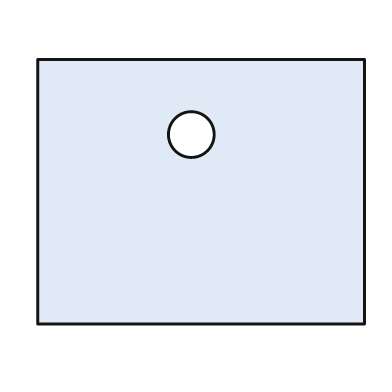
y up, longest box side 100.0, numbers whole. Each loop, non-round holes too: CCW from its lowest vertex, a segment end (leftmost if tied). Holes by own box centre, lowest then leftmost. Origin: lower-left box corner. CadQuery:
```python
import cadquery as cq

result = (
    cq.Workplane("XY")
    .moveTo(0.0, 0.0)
    .lineTo(100.0, 0.0)
    .lineTo(100.0, 81.0)
    .lineTo(0.0, 81.0)
    .close()
    .moveTo(47.0, 58.0)
    .circle(7.0)
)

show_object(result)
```